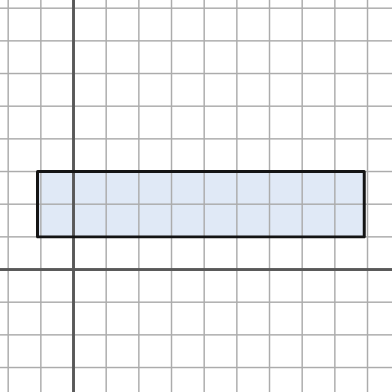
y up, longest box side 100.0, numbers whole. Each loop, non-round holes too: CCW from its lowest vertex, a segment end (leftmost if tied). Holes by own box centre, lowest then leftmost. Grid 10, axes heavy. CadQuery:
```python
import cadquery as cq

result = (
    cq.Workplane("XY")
    .moveTo(-11.0, 10.0)
    .lineTo(89.0, 10.0)
    .lineTo(89.0, 30.0)
    .lineTo(-11.0, 30.0)
    .close()
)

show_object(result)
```